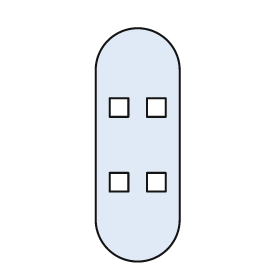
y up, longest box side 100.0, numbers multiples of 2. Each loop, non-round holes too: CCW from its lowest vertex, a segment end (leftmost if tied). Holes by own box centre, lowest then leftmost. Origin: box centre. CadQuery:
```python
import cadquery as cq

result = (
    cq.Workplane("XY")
    .moveTo(-18.0, -32.0)
    .threePointArc((0.0, -50.0), (18.0, -32.0))
    .lineTo(18.0, 32.0)
    .threePointArc((0.0, 50.0), (-18.0, 32.0))
    .close()
    .moveTo(-12.0, -20.0)
    .lineTo(-4.0, -20.0)
    .lineTo(-4.0, -12.0)
    .lineTo(-12.0, -12.0)
    .close()
    .moveTo(4.0, -20.0)
    .lineTo(12.0, -20.0)
    .lineTo(12.0, -12.0)
    .lineTo(4.0, -12.0)
    .close()
    .moveTo(-12.0, 12.0)
    .lineTo(-4.0, 12.0)
    .lineTo(-4.0, 20.0)
    .lineTo(-12.0, 20.0)
    .close()
    .moveTo(4.0, 12.0)
    .lineTo(12.0, 12.0)
    .lineTo(12.0, 20.0)
    .lineTo(4.0, 20.0)
    .close()
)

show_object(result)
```